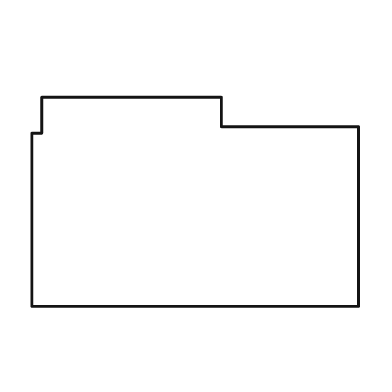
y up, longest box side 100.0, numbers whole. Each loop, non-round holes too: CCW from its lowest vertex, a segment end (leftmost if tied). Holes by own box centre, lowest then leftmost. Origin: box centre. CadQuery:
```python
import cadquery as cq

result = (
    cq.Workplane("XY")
    .moveTo(-50.0, -32.0)
    .lineTo(50.0, -32.0)
    .lineTo(50.0, 23.0)
    .lineTo(8.0, 23.0)
    .lineTo(8.0, 32.0)
    .lineTo(-47.0, 32.0)
    .lineTo(-47.0, 21.0)
    .lineTo(-50.0, 21.0)
    .close()
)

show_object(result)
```